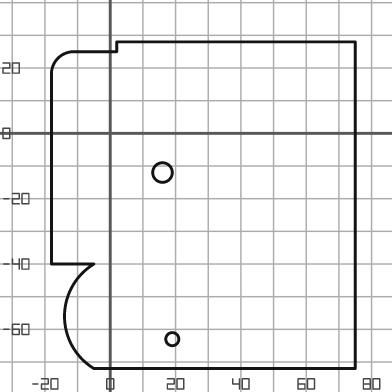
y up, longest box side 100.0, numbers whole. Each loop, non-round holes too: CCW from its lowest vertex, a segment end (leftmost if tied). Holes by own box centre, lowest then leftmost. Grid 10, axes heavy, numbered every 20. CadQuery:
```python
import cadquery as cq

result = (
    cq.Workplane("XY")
    .moveTo(-5.0, -72.0)
    .lineTo(75.0, -72.0)
    .lineTo(75.0, 28.0)
    .lineTo(2.0, 28.0)
    .lineTo(2.0, 25.0)
    .lineTo(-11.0, 25.0)
    .threePointArc((-16.0, 23.0), (-18.0, 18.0))
    .lineTo(-18.0, -40.0)
    .lineTo(-5.0, -40.0)
    .threePointArc((-14.0, -56.0), (-5.0, -72.0))
    .close()
    .moveTo(19.0, -63.0)
    .circle(2.0)
    .moveTo(16.0, -12.0)
    .circle(3.0)
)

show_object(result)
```